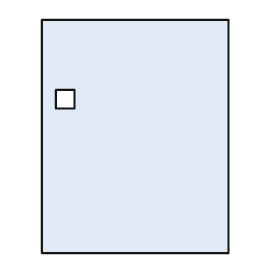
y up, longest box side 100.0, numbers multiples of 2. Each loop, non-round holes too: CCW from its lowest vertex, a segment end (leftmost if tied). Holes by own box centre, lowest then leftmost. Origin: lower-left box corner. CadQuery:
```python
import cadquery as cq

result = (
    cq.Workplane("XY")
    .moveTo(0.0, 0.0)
    .lineTo(80.0, 0.0)
    .lineTo(80.0, 100.0)
    .lineTo(0.0, 100.0)
    .close()
    .moveTo(6.0, 62.0)
    .lineTo(14.0, 62.0)
    .lineTo(14.0, 70.0)
    .lineTo(6.0, 70.0)
    .close()
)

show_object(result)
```